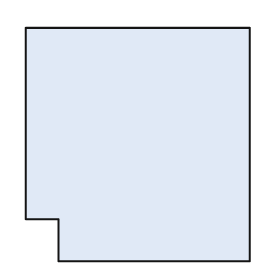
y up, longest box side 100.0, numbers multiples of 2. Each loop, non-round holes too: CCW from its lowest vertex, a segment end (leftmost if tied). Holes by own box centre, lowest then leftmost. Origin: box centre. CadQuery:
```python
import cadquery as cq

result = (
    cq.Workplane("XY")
    .moveTo(-34.0, -50.0)
    .lineTo(48.0, -50.0)
    .lineTo(48.0, 50.0)
    .lineTo(-48.0, 50.0)
    .lineTo(-48.0, -32.0)
    .lineTo(-34.0, -32.0)
    .close()
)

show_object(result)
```